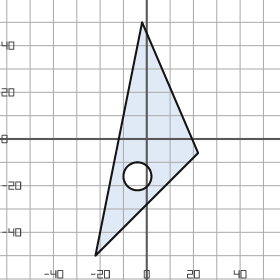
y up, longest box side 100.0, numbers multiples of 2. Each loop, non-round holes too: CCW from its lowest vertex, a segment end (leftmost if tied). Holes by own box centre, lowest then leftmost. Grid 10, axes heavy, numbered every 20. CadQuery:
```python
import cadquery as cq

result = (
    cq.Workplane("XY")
    .moveTo(-22.0, -50.0)
    .lineTo(22.0, -6.0)
    .lineTo(-2.0, 50.0)
    .close()
    .moveTo(-4.0, -16.0)
    .circle(6.0)
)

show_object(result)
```